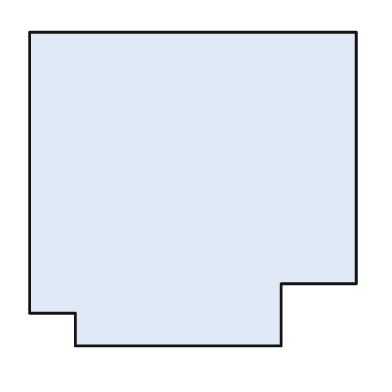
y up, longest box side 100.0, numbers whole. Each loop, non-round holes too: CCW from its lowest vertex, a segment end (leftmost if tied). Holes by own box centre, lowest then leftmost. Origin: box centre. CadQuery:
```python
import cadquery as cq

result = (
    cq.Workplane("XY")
    .moveTo(-36.0, -48.0)
    .lineTo(27.0, -48.0)
    .lineTo(27.0, -29.0)
    .lineTo(50.0, -29.0)
    .lineTo(50.0, 48.0)
    .lineTo(-50.0, 48.0)
    .lineTo(-50.0, -38.0)
    .lineTo(-36.0, -38.0)
    .close()
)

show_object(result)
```